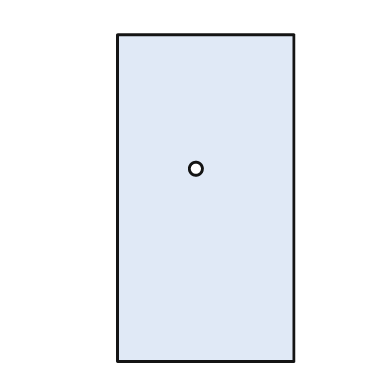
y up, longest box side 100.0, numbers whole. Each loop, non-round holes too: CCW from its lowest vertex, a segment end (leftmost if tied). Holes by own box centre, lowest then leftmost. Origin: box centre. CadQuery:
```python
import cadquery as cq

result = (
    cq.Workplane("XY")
    .moveTo(-27.0, -50.0)
    .lineTo(27.0, -50.0)
    .lineTo(27.0, 50.0)
    .lineTo(-27.0, 50.0)
    .close()
    .moveTo(-3.0, 9.0)
    .circle(2.0)
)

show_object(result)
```